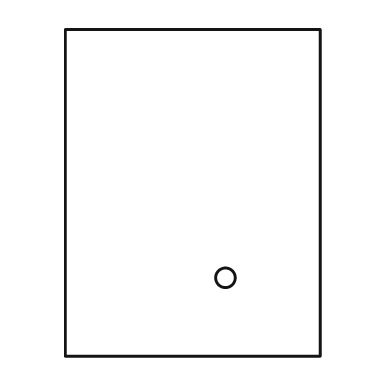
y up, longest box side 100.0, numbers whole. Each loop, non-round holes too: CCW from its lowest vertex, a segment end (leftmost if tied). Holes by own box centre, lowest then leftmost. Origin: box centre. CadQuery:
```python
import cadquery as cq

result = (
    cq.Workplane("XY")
    .moveTo(-39.0, -50.0)
    .lineTo(39.0, -50.0)
    .lineTo(39.0, 50.0)
    .lineTo(-39.0, 50.0)
    .close()
    .moveTo(10.0, -26.0)
    .circle(3.0)
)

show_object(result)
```